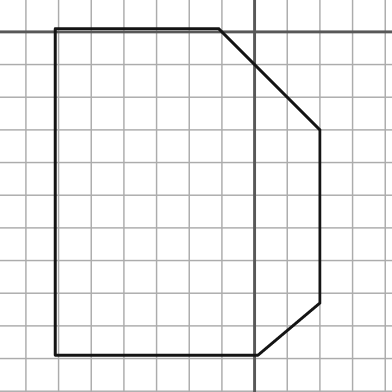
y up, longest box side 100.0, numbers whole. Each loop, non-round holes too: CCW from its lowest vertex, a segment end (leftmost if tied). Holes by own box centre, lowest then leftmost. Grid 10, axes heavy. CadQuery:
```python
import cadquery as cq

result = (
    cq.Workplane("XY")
    .moveTo(-61.0, -99.0)
    .lineTo(1.0, -99.0)
    .lineTo(20.0, -83.0)
    .lineTo(20.0, -30.0)
    .lineTo(-11.0, 1.0)
    .lineTo(-61.0, 1.0)
    .close()
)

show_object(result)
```